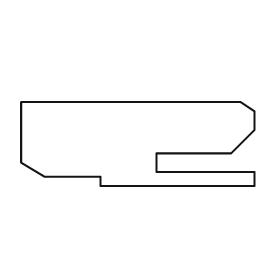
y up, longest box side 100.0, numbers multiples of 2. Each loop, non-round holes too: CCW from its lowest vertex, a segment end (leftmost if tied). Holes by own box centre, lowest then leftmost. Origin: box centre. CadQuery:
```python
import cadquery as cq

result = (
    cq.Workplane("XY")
    .moveTo(-16.0, -18.0)
    .lineTo(50.0, -18.0)
    .lineTo(50.0, -12.0)
    .lineTo(8.0, -12.0)
    .lineTo(8.0, -4.0)
    .lineTo(40.0, -4.0)
    .lineTo(50.0, 6.0)
    .lineTo(50.0, 14.0)
    .lineTo(44.0, 18.0)
    .lineTo(-50.0, 18.0)
    .lineTo(-50.0, -8.0)
    .lineTo(-40.0, -14.0)
    .lineTo(-16.0, -14.0)
    .close()
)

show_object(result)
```